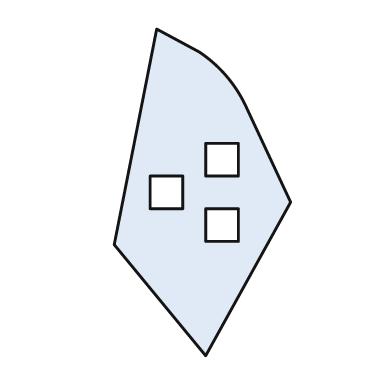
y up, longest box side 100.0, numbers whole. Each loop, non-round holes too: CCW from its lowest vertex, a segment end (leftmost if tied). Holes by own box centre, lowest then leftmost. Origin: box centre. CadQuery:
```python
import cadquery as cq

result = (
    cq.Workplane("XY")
    .moveTo(1.0, -50.0)
    .lineTo(27.0, -3.0)
    .lineTo(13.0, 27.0)
    .threePointArc((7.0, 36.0), (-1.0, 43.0))
    .lineTo(-14.0, 50.0)
    .lineTo(-27.0, -16.0)
    .close()
    .moveTo(1.0, -15.0)
    .lineTo(11.0, -15.0)
    .lineTo(11.0, -5.0)
    .lineTo(1.0, -5.0)
    .close()
    .moveTo(-16.0, -5.0)
    .lineTo(-6.0, -5.0)
    .lineTo(-6.0, 5.0)
    .lineTo(-16.0, 5.0)
    .close()
    .moveTo(1.0, 5.0)
    .lineTo(11.0, 5.0)
    .lineTo(11.0, 15.0)
    .lineTo(1.0, 15.0)
    .close()
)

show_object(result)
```